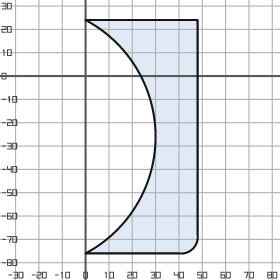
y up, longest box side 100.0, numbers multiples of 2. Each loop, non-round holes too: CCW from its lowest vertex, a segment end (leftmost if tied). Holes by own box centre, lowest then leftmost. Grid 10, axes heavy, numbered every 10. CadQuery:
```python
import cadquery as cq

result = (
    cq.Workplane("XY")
    .moveTo(0.0, -76.0)
    .lineTo(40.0, -76.0)
    .threePointArc((46.0, -74.0), (48.0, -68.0))
    .lineTo(48.0, 24.0)
    .lineTo(0.0, 24.0)
    .threePointArc((30.0, -26.0), (0.0, -76.0))
    .close()
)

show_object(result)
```